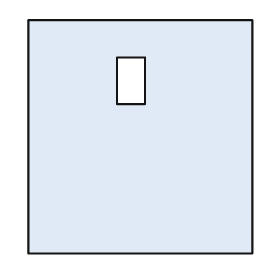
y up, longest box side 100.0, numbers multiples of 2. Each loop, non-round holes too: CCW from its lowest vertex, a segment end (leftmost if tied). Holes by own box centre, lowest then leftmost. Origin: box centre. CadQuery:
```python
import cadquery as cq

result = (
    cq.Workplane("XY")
    .moveTo(-48.0, -50.0)
    .lineTo(48.0, -50.0)
    .lineTo(48.0, 50.0)
    .lineTo(-48.0, 50.0)
    .close()
    .moveTo(-10.0, 14.0)
    .lineTo(2.0, 14.0)
    .lineTo(2.0, 34.0)
    .lineTo(-10.0, 34.0)
    .close()
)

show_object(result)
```